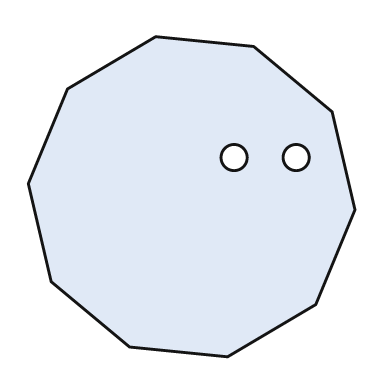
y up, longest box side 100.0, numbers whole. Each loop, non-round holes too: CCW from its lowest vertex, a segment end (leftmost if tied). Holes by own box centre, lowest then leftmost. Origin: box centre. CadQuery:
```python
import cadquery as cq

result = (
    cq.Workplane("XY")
    .moveTo(11.0, -49.0)
    .lineTo(38.0, -33.0)
    .lineTo(50.0, -4.0)
    .lineTo(43.0, 26.0)
    .lineTo(19.0, 46.0)
    .lineTo(-11.0, 49.0)
    .lineTo(-38.0, 33.0)
    .lineTo(-50.0, 4.0)
    .lineTo(-43.0, -26.0)
    .lineTo(-19.0, -46.0)
    .close()
    .moveTo(13.0, 12.0)
    .circle(4.0)
    .moveTo(32.0, 12.0)
    .circle(4.0)
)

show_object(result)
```